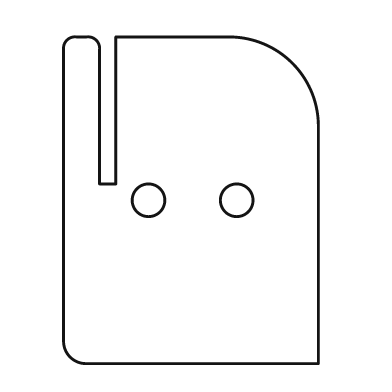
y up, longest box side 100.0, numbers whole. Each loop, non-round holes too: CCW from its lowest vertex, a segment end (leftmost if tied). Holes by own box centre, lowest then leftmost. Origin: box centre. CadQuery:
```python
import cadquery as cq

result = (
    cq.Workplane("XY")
    .moveTo(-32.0, -50.0)
    .lineTo(39.0, -50.0)
    .lineTo(39.0, 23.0)
    .threePointArc((31.0, 42.0), (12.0, 50.0))
    .lineTo(-23.0, 50.0)
    .lineTo(-23.0, 5.0)
    .lineTo(-28.0, 5.0)
    .lineTo(-28.0, 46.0)
    .threePointArc((-29.0, 49.0), (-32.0, 50.0))
    .lineTo(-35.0, 50.0)
    .threePointArc((-38.0, 49.0), (-39.0, 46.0))
    .lineTo(-39.0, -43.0)
    .threePointArc((-37.0, -48.0), (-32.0, -50.0))
    .close()
    .moveTo(-13.0, 0.0)
    .circle(5.0)
    .moveTo(14.0, 0.0)
    .circle(5.0)
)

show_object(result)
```